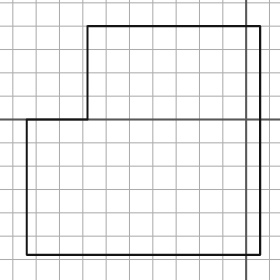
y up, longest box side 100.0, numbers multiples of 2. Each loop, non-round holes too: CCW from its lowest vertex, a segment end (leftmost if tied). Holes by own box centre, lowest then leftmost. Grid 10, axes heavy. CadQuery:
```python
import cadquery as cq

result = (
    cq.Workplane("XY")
    .moveTo(-94.0, -58.0)
    .lineTo(6.0, -58.0)
    .lineTo(6.0, 40.0)
    .lineTo(-68.0, 40.0)
    .lineTo(-68.0, 0.0)
    .lineTo(-94.0, 0.0)
    .close()
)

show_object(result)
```